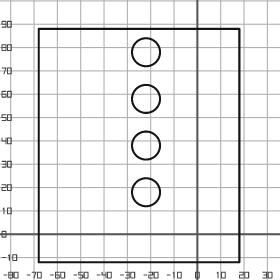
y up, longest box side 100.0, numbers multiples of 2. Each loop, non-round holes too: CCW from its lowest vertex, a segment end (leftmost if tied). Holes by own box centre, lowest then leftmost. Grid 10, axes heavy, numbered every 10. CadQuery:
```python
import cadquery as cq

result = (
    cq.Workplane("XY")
    .moveTo(-68.0, -12.0)
    .lineTo(18.0, -12.0)
    .lineTo(18.0, 88.0)
    .lineTo(-68.0, 88.0)
    .close()
    .moveTo(-22.0, 18.0)
    .circle(6.0)
    .moveTo(-22.0, 38.0)
    .circle(6.0)
    .moveTo(-22.0, 58.0)
    .circle(6.0)
    .moveTo(-22.0, 78.0)
    .circle(6.0)
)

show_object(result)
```